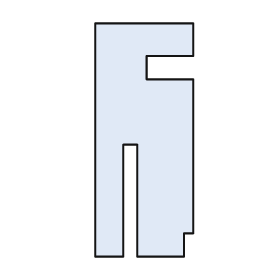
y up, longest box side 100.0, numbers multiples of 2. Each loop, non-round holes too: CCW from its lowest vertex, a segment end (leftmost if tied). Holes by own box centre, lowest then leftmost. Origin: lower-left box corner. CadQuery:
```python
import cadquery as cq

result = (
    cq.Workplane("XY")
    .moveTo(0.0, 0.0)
    .lineTo(12.0, 0.0)
    .lineTo(12.0, 48.0)
    .lineTo(18.0, 48.0)
    .lineTo(18.0, 0.0)
    .lineTo(38.0, 0.0)
    .lineTo(38.0, 10.0)
    .lineTo(42.0, 10.0)
    .lineTo(42.0, 76.0)
    .lineTo(22.0, 76.0)
    .lineTo(22.0, 86.0)
    .lineTo(42.0, 86.0)
    .lineTo(42.0, 100.0)
    .lineTo(0.0, 100.0)
    .close()
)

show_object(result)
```